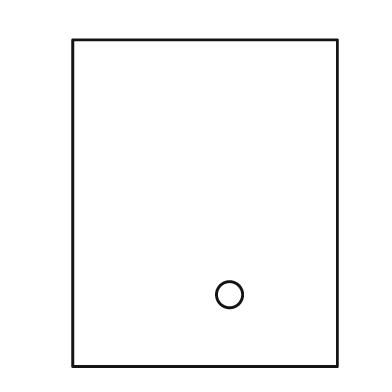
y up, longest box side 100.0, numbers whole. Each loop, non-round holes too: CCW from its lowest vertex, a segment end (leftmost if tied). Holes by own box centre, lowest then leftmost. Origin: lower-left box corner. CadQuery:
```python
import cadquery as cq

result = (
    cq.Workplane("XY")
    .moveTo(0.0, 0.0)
    .lineTo(81.0, 0.0)
    .lineTo(81.0, 100.0)
    .lineTo(0.0, 100.0)
    .close()
    .moveTo(48.0, 22.0)
    .circle(4.0)
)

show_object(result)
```